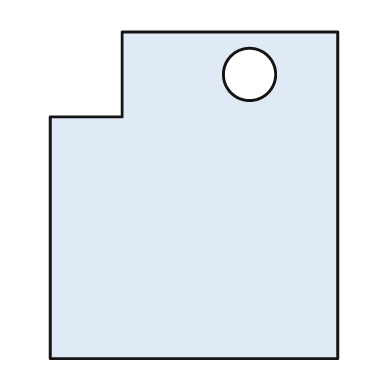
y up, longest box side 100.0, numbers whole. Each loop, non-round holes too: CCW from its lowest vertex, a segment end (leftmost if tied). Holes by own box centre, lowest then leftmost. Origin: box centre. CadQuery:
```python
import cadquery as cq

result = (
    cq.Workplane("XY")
    .moveTo(-44.0, -50.0)
    .lineTo(44.0, -50.0)
    .lineTo(44.0, 50.0)
    .lineTo(-22.0, 50.0)
    .lineTo(-22.0, 24.0)
    .lineTo(-44.0, 24.0)
    .close()
    .moveTo(17.0, 37.0)
    .circle(8.0)
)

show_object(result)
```